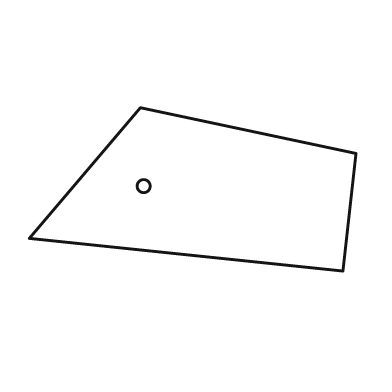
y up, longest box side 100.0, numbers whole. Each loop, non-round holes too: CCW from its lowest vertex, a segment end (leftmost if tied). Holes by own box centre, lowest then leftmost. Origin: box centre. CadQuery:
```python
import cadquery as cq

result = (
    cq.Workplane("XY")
    .moveTo(46.0, -25.0)
    .lineTo(50.0, 11.0)
    .lineTo(-16.0, 25.0)
    .lineTo(-50.0, -15.0)
    .close()
    .moveTo(-15.0, 1.0)
    .circle(2.0)
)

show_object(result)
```